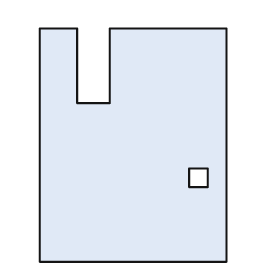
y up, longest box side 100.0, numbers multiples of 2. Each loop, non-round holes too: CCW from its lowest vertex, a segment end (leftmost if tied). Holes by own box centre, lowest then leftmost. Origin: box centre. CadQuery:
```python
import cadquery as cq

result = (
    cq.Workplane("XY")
    .moveTo(-40.0, -50.0)
    .lineTo(40.0, -50.0)
    .lineTo(40.0, 50.0)
    .lineTo(-10.0, 50.0)
    .lineTo(-10.0, 18.0)
    .lineTo(-24.0, 18.0)
    .lineTo(-24.0, 50.0)
    .lineTo(-40.0, 50.0)
    .close()
    .moveTo(24.0, -18.0)
    .lineTo(32.0, -18.0)
    .lineTo(32.0, -10.0)
    .lineTo(24.0, -10.0)
    .close()
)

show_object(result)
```